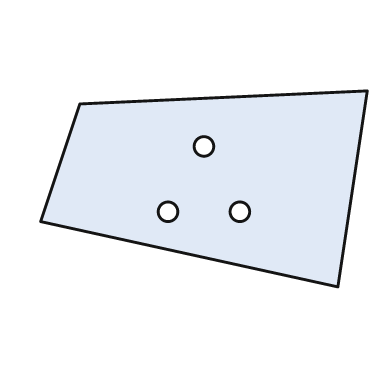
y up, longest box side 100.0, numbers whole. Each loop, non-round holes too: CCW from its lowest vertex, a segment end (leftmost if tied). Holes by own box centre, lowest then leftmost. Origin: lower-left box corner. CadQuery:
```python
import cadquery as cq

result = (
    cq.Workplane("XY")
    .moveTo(91.0, 0.0)
    .lineTo(100.0, 60.0)
    .lineTo(12.0, 56.0)
    .lineTo(0.0, 20.0)
    .close()
    .moveTo(39.0, 23.0)
    .circle(3.0)
    .moveTo(61.0, 23.0)
    .circle(3.0)
    .moveTo(50.0, 43.0)
    .circle(3.0)
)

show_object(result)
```